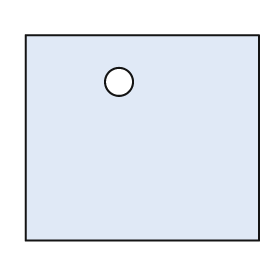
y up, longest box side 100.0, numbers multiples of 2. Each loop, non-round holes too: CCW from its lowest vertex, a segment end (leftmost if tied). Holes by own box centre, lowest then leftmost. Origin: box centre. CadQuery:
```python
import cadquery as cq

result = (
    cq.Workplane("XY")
    .moveTo(-50.0, -44.0)
    .lineTo(50.0, -44.0)
    .lineTo(50.0, 44.0)
    .lineTo(-50.0, 44.0)
    .close()
    .moveTo(-10.0, 24.0)
    .circle(6.0)
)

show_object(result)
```